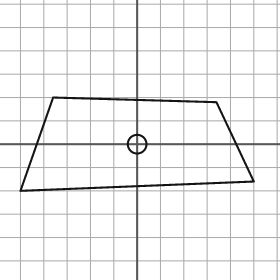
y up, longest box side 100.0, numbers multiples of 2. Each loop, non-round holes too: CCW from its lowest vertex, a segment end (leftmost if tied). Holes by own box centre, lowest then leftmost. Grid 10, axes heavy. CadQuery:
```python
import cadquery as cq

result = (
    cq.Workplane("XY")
    .moveTo(-50.0, -20.0)
    .lineTo(50.0, -16.0)
    .lineTo(34.0, 18.0)
    .lineTo(-36.0, 20.0)
    .close()
    .moveTo(0.0, 0.0)
    .circle(4.0)
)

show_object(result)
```